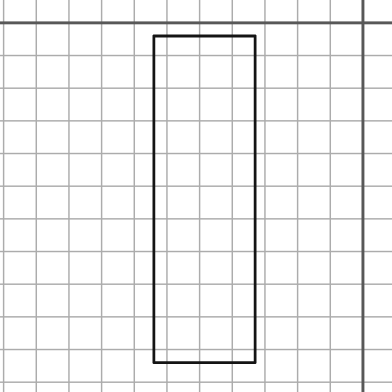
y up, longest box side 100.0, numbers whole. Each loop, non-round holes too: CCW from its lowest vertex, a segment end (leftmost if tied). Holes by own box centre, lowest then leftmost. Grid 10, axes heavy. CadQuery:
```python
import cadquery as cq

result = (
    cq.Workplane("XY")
    .moveTo(-64.0, -104.0)
    .lineTo(-33.0, -104.0)
    .lineTo(-33.0, -4.0)
    .lineTo(-64.0, -4.0)
    .close()
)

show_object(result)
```